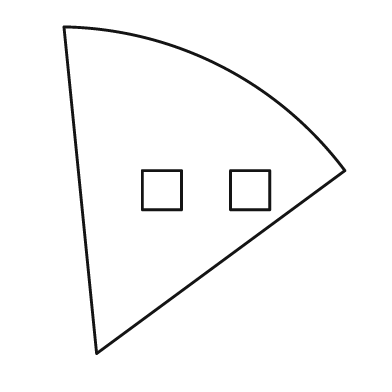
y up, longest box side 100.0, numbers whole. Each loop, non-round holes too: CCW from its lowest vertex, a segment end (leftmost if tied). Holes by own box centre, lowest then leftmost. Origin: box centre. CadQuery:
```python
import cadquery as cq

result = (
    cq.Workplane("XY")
    .moveTo(-33.0, -50.0)
    .lineTo(43.0, 6.0)
    .threePointArc((5.0, 38.0), (-43.0, 50.0))
    .close()
    .moveTo(-19.0, -6.0)
    .lineTo(-7.0, -6.0)
    .lineTo(-7.0, 6.0)
    .lineTo(-19.0, 6.0)
    .close()
    .moveTo(8.0, -6.0)
    .lineTo(20.0, -6.0)
    .lineTo(20.0, 6.0)
    .lineTo(8.0, 6.0)
    .close()
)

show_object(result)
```